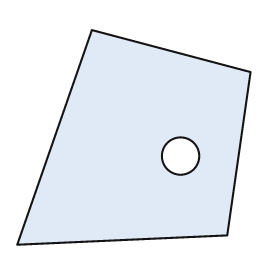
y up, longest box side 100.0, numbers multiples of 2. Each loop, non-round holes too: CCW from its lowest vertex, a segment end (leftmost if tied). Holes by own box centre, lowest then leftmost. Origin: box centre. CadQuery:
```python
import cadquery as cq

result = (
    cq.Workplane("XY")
    .moveTo(-50.0, -46.0)
    .lineTo(40.0, -42.0)
    .lineTo(50.0, 28.0)
    .lineTo(-18.0, 46.0)
    .close()
    .moveTo(20.0, -8.0)
    .circle(8.0)
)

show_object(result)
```